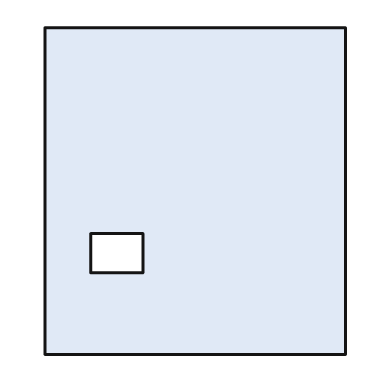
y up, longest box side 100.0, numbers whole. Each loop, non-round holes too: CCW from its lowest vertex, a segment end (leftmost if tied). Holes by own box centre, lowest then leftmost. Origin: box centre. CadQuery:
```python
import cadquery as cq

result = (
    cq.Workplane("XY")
    .moveTo(-46.0, -50.0)
    .lineTo(46.0, -50.0)
    .lineTo(46.0, 50.0)
    .lineTo(-46.0, 50.0)
    .close()
    .moveTo(-32.0, -25.0)
    .lineTo(-16.0, -25.0)
    .lineTo(-16.0, -13.0)
    .lineTo(-32.0, -13.0)
    .close()
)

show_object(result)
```